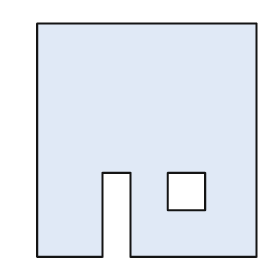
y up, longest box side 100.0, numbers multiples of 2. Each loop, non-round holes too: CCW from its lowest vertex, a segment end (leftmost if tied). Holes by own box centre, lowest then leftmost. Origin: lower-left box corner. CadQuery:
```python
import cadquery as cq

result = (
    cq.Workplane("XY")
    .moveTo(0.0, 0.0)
    .lineTo(28.0, 0.0)
    .lineTo(28.0, 36.0)
    .lineTo(40.0, 36.0)
    .lineTo(40.0, 0.0)
    .lineTo(94.0, 0.0)
    .lineTo(94.0, 100.0)
    .lineTo(0.0, 100.0)
    .close()
    .moveTo(56.0, 20.0)
    .lineTo(72.0, 20.0)
    .lineTo(72.0, 36.0)
    .lineTo(56.0, 36.0)
    .close()
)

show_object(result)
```